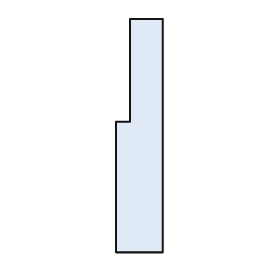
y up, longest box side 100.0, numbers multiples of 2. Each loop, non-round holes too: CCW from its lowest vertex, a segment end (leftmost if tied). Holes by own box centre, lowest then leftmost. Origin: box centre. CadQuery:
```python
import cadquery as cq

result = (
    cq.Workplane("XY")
    .moveTo(-10.0, -50.0)
    .lineTo(10.0, -50.0)
    .lineTo(10.0, 50.0)
    .lineTo(-4.0, 50.0)
    .lineTo(-4.0, 6.0)
    .lineTo(-10.0, 6.0)
    .close()
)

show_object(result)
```